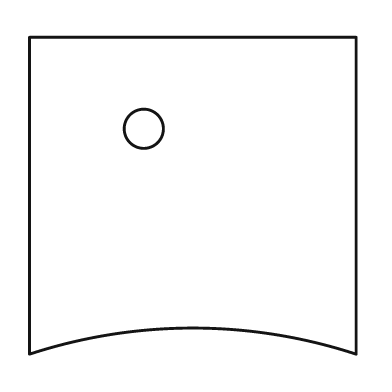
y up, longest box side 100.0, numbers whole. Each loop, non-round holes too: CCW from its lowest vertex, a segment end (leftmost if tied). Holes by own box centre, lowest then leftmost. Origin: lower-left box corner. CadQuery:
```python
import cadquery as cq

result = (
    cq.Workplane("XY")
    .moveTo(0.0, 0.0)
    .threePointArc((50.0, 8.0), (100.0, 0.0))
    .lineTo(100.0, 97.0)
    .lineTo(0.0, 97.0)
    .close()
    .moveTo(35.0, 69.0)
    .circle(6.0)
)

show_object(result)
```